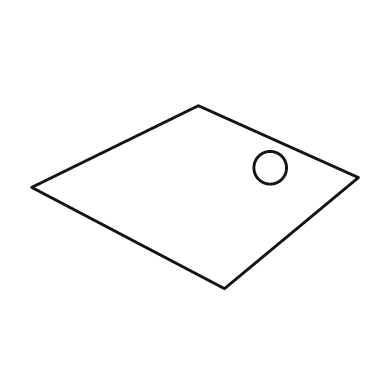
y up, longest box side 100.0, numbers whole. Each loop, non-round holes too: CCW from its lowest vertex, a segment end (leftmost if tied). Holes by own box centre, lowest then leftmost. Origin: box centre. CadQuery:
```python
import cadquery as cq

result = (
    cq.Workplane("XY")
    .moveTo(9.0, -28.0)
    .lineTo(50.0, 6.0)
    .lineTo(1.0, 28.0)
    .lineTo(-50.0, 3.0)
    .close()
    .moveTo(23.0, 9.0)
    .circle(5.0)
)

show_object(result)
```